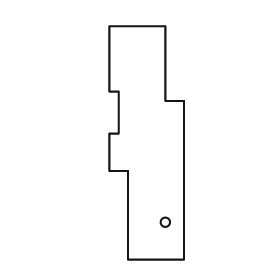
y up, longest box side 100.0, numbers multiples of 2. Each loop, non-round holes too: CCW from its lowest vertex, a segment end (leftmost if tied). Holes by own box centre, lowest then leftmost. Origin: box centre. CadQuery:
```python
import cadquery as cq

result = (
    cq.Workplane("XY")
    .moveTo(-8.0, -50.0)
    .lineTo(16.0, -50.0)
    .lineTo(16.0, 18.0)
    .lineTo(8.0, 18.0)
    .lineTo(8.0, 50.0)
    .lineTo(-16.0, 50.0)
    .lineTo(-16.0, 22.0)
    .lineTo(-12.0, 22.0)
    .lineTo(-12.0, 4.0)
    .lineTo(-16.0, 4.0)
    .lineTo(-16.0, -12.0)
    .lineTo(-8.0, -12.0)
    .close()
    .moveTo(8.0, -34.0)
    .circle(2.0)
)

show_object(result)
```